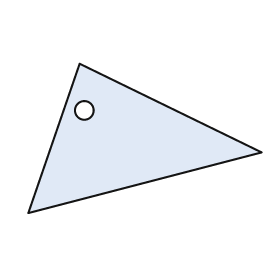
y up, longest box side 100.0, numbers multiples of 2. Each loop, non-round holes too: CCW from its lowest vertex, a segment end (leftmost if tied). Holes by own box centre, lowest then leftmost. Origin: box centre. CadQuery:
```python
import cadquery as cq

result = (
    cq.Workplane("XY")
    .moveTo(-50.0, -32.0)
    .lineTo(50.0, -6.0)
    .lineTo(-28.0, 32.0)
    .close()
    .moveTo(-26.0, 12.0)
    .circle(4.0)
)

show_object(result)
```